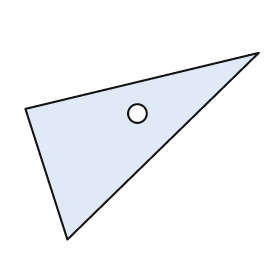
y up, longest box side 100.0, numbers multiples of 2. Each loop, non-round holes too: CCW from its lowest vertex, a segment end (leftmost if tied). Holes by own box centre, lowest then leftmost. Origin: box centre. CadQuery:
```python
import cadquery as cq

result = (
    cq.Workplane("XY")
    .moveTo(-32.0, -40.0)
    .lineTo(50.0, 40.0)
    .lineTo(-50.0, 16.0)
    .close()
    .moveTo(-2.0, 14.0)
    .circle(4.0)
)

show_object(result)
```